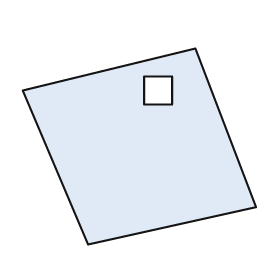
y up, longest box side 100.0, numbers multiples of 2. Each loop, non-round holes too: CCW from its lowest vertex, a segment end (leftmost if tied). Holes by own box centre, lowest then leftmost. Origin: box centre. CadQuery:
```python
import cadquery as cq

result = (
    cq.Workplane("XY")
    .moveTo(-22.0, -42.0)
    .lineTo(50.0, -26.0)
    .lineTo(24.0, 42.0)
    .lineTo(-50.0, 24.0)
    .close()
    .moveTo(2.0, 18.0)
    .lineTo(14.0, 18.0)
    .lineTo(14.0, 30.0)
    .lineTo(2.0, 30.0)
    .close()
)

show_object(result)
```